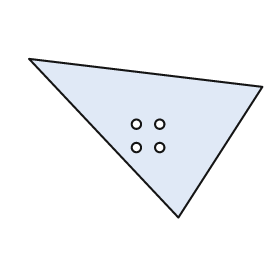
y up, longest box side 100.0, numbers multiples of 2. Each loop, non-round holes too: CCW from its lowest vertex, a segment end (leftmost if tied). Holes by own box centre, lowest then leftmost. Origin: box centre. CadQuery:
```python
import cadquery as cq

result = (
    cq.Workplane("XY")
    .moveTo(14.0, -34.0)
    .lineTo(50.0, 22.0)
    .lineTo(-50.0, 34.0)
    .close()
    .moveTo(-4.0, -4.0)
    .circle(2.0)
    .moveTo(6.0, -4.0)
    .circle(2.0)
    .moveTo(-4.0, 6.0)
    .circle(2.0)
    .moveTo(6.0, 6.0)
    .circle(2.0)
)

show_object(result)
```